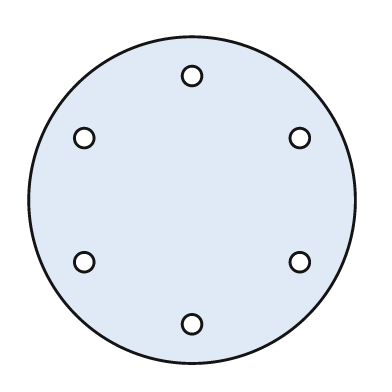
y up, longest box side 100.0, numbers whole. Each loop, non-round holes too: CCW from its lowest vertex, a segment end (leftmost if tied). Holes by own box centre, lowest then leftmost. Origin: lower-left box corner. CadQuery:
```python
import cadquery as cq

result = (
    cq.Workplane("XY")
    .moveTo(50.0, 50.0)
    .circle(50.0)
    .moveTo(50.0, 12.0)
    .circle(3.0)
    .moveTo(17.0, 31.0)
    .circle(3.0)
    .moveTo(83.0, 31.0)
    .circle(3.0)
    .moveTo(17.0, 69.0)
    .circle(3.0)
    .moveTo(83.0, 69.0)
    .circle(3.0)
    .moveTo(50.0, 88.0)
    .circle(3.0)
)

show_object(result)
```